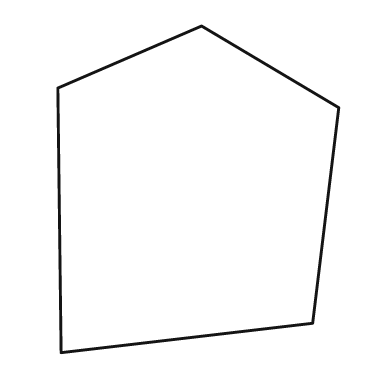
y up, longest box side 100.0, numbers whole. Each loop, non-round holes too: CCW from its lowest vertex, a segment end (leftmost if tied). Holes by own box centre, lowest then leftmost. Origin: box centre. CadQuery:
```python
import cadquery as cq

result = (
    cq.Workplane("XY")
    .moveTo(-42.0, -50.0)
    .lineTo(35.0, -41.0)
    .lineTo(43.0, 25.0)
    .lineTo(1.0, 50.0)
    .lineTo(-43.0, 31.0)
    .close()
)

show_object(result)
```